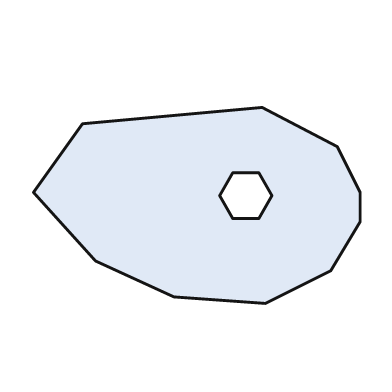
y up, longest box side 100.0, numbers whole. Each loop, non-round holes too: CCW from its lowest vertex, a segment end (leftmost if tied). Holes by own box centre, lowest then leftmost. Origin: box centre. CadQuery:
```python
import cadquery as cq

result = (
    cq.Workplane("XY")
    .moveTo(21.0, -30.0)
    .lineTo(41.0, -20.0)
    .lineTo(50.0, -5.0)
    .lineTo(50.0, 4.0)
    .lineTo(43.0, 18.0)
    .lineTo(20.0, 30.0)
    .lineTo(-35.0, 25.0)
    .lineTo(-50.0, 4.0)
    .lineTo(-31.0, -17.0)
    .lineTo(-7.0, -28.0)
    .close()
    .moveTo(11.0, -4.0)
    .lineTo(19.0, -4.0)
    .lineTo(23.0, 3.0)
    .lineTo(19.0, 10.0)
    .lineTo(11.0, 10.0)
    .lineTo(7.0, 3.0)
    .close()
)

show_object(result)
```